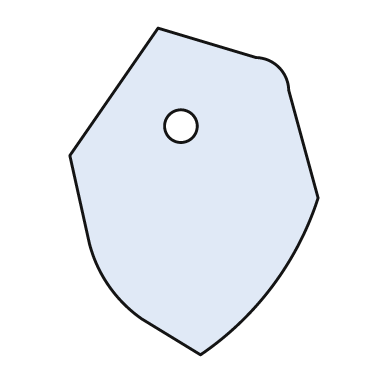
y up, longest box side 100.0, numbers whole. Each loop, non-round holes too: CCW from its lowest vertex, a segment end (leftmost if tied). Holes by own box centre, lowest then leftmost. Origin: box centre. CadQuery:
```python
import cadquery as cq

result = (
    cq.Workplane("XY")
    .moveTo(2.0, -50.0)
    .threePointArc((24.0, -29.0), (38.0, -2.0))
    .lineTo(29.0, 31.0)
    .threePointArc((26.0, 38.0), (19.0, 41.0))
    .lineTo(-11.0, 50.0)
    .lineTo(-38.0, 11.0)
    .lineTo(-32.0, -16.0)
    .threePointArc((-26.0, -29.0), (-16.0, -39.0))
    .close()
    .moveTo(-4.0, 20.0)
    .circle(5.0)
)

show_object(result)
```